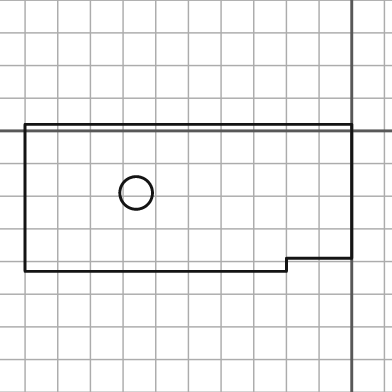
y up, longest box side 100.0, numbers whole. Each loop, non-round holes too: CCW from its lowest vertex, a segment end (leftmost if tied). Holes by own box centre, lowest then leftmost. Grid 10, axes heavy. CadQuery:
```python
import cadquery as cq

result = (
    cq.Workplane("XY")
    .moveTo(-100.0, -43.0)
    .lineTo(-20.0, -43.0)
    .lineTo(-20.0, -39.0)
    .lineTo(0.0, -39.0)
    .lineTo(0.0, 2.0)
    .lineTo(-100.0, 2.0)
    .close()
    .moveTo(-66.0, -19.0)
    .circle(5.0)
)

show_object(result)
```